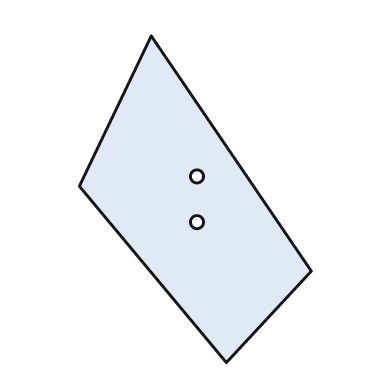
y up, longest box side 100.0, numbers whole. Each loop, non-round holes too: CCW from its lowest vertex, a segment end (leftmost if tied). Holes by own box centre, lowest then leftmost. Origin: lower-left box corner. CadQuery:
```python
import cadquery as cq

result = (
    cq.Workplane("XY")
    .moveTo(45.0, 0.0)
    .lineTo(71.0, 28.0)
    .lineTo(22.0, 100.0)
    .lineTo(0.0, 54.0)
    .close()
    .moveTo(36.0, 43.0)
    .circle(2.0)
    .moveTo(36.0, 57.0)
    .circle(2.0)
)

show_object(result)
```